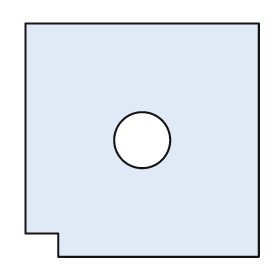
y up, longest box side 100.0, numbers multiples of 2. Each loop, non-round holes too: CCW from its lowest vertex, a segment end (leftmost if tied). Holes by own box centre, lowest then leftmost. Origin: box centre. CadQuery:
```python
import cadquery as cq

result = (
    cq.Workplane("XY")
    .moveTo(-36.0, -50.0)
    .lineTo(50.0, -50.0)
    .lineTo(50.0, 50.0)
    .lineTo(-50.0, 50.0)
    .lineTo(-50.0, -40.0)
    .lineTo(-36.0, -40.0)
    .close()
    .moveTo(0.0, 0.0)
    .circle(12.0)
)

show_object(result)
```